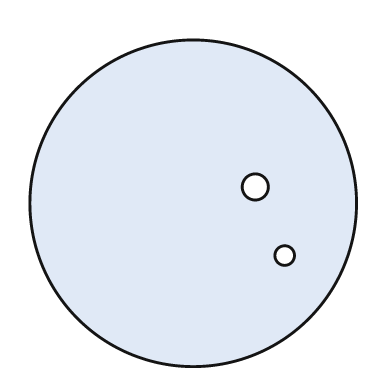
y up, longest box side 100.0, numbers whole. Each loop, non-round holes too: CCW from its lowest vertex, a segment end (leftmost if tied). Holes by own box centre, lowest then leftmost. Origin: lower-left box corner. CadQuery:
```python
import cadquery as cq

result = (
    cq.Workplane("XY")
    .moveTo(50.0, 50.0)
    .circle(50.0)
    .moveTo(78.0, 34.0)
    .circle(3.0)
    .moveTo(69.0, 55.0)
    .circle(4.0)
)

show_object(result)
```